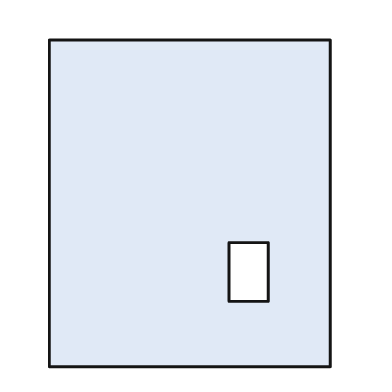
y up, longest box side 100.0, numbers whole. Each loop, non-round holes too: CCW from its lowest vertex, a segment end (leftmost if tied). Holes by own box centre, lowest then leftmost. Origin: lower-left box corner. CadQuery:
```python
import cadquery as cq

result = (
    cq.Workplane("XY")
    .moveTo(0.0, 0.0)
    .lineTo(86.0, 0.0)
    .lineTo(86.0, 100.0)
    .lineTo(0.0, 100.0)
    .close()
    .moveTo(55.0, 20.0)
    .lineTo(67.0, 20.0)
    .lineTo(67.0, 38.0)
    .lineTo(55.0, 38.0)
    .close()
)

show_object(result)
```